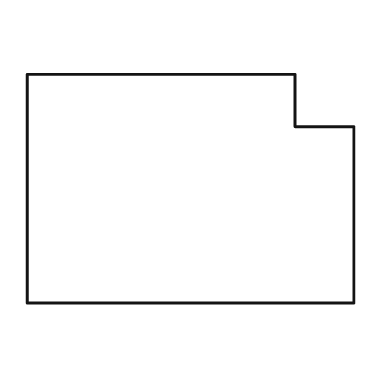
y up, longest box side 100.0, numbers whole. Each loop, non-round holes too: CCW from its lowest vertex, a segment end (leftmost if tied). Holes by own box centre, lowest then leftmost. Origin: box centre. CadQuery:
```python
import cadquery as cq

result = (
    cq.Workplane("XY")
    .moveTo(-50.0, -35.0)
    .lineTo(50.0, -35.0)
    .lineTo(50.0, 19.0)
    .lineTo(32.0, 19.0)
    .lineTo(32.0, 35.0)
    .lineTo(-50.0, 35.0)
    .close()
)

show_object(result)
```